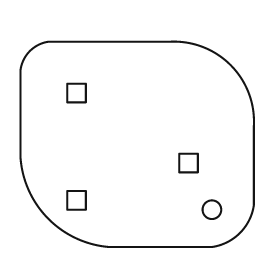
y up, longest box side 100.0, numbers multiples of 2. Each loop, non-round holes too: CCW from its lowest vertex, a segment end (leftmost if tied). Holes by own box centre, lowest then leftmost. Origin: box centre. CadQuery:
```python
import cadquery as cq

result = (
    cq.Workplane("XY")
    .moveTo(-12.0, -44.0)
    .lineTo(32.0, -44.0)
    .threePointArc((44.0, -38.0), (50.0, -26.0))
    .lineTo(50.0, 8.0)
    .threePointArc((40.0, 34.0), (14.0, 44.0))
    .lineTo(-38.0, 44.0)
    .threePointArc((-46.0, 40.0), (-50.0, 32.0))
    .lineTo(-50.0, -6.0)
    .threePointArc((-38.0, -32.0), (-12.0, -44.0))
    .close()
    .moveTo(32.0, -28.0)
    .circle(4.0)
    .moveTo(-30.0, -28.0)
    .lineTo(-22.0, -28.0)
    .lineTo(-22.0, -20.0)
    .lineTo(-30.0, -20.0)
    .close()
    .moveTo(18.0, -12.0)
    .lineTo(26.0, -12.0)
    .lineTo(26.0, -4.0)
    .lineTo(18.0, -4.0)
    .close()
    .moveTo(-30.0, 18.0)
    .lineTo(-22.0, 18.0)
    .lineTo(-22.0, 26.0)
    .lineTo(-30.0, 26.0)
    .close()
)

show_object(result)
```